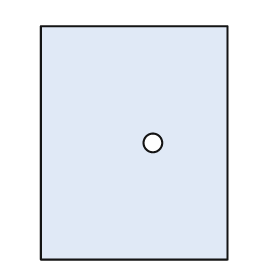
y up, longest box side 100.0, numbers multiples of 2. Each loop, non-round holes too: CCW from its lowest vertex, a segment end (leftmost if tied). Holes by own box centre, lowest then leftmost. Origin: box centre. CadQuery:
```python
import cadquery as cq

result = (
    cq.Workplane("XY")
    .moveTo(-40.0, -50.0)
    .lineTo(40.0, -50.0)
    .lineTo(40.0, 50.0)
    .lineTo(-40.0, 50.0)
    .close()
    .moveTo(8.0, 0.0)
    .circle(4.0)
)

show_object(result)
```